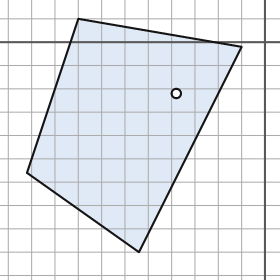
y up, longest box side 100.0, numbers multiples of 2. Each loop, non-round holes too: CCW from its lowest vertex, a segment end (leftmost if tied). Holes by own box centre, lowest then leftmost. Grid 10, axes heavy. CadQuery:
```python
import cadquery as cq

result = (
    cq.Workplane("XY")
    .moveTo(-54.0, -90.0)
    .lineTo(-10.0, -2.0)
    .lineTo(-80.0, 10.0)
    .lineTo(-102.0, -56.0)
    .close()
    .moveTo(-38.0, -22.0)
    .circle(2.0)
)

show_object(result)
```